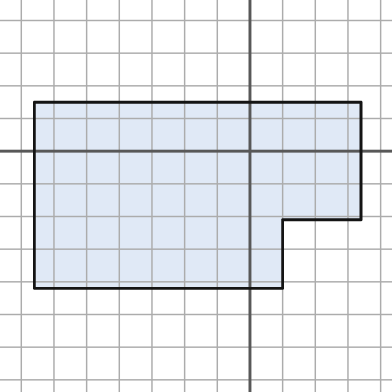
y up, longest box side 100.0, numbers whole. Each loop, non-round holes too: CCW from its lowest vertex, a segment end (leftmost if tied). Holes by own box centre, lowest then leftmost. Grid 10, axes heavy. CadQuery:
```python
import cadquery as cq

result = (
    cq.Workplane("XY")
    .moveTo(-66.0, -42.0)
    .lineTo(10.0, -42.0)
    .lineTo(10.0, -21.0)
    .lineTo(34.0, -21.0)
    .lineTo(34.0, 15.0)
    .lineTo(-66.0, 15.0)
    .close()
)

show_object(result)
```